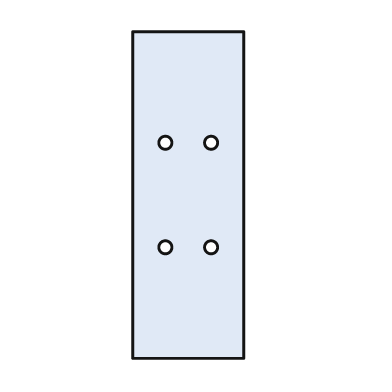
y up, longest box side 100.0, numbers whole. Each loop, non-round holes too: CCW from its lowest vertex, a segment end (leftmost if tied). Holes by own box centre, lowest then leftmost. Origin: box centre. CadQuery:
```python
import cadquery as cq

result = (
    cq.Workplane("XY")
    .moveTo(-17.0, -50.0)
    .lineTo(17.0, -50.0)
    .lineTo(17.0, 50.0)
    .lineTo(-17.0, 50.0)
    .close()
    .moveTo(-7.0, -16.0)
    .circle(2.0)
    .moveTo(7.0, -16.0)
    .circle(2.0)
    .moveTo(-7.0, 16.0)
    .circle(2.0)
    .moveTo(7.0, 16.0)
    .circle(2.0)
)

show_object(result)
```